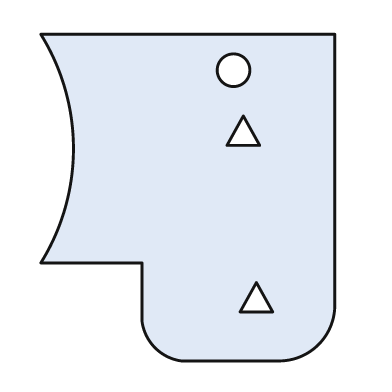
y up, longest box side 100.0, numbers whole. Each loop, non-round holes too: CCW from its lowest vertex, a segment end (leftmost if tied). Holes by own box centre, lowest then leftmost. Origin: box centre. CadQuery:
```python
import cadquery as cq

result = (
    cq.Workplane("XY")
    .moveTo(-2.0, -50.0)
    .lineTo(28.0, -50.0)
    .threePointArc((40.0, -45.0), (45.0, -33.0))
    .lineTo(45.0, 50.0)
    .lineTo(-45.0, 50.0)
    .threePointArc((-35.0, 15.0), (-45.0, -20.0))
    .lineTo(-14.0, -20.0)
    .lineTo(-14.0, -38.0)
    .threePointArc((-10.0, -46.0), (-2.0, -50.0))
    .close()
    .moveTo(16.0, -35.0)
    .lineTo(26.0, -35.0)
    .lineTo(21.0, -26.0)
    .close()
    .moveTo(12.0, 16.0)
    .lineTo(22.0, 16.0)
    .lineTo(17.0, 25.0)
    .close()
    .moveTo(14.0, 39.0)
    .circle(5.0)
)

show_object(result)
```